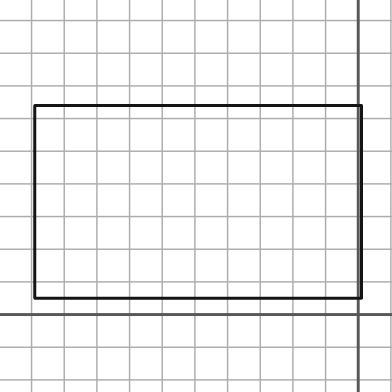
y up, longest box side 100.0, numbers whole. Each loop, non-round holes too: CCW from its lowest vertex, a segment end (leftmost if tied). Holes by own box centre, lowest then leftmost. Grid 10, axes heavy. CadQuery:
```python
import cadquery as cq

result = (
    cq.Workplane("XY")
    .moveTo(-99.0, 5.0)
    .lineTo(1.0, 5.0)
    .lineTo(1.0, 64.0)
    .lineTo(-99.0, 64.0)
    .close()
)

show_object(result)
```